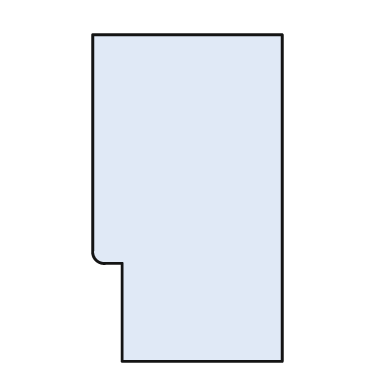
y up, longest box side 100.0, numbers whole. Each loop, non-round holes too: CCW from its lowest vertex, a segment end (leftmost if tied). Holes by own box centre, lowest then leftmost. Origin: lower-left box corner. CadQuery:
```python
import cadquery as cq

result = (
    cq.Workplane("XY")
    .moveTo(9.0, 0.0)
    .lineTo(58.0, 0.0)
    .lineTo(58.0, 100.0)
    .lineTo(0.0, 100.0)
    .lineTo(0.0, 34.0)
    .threePointArc((1.0, 31.0), (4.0, 30.0))
    .lineTo(9.0, 30.0)
    .close()
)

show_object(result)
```